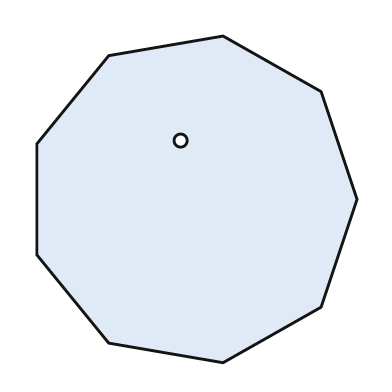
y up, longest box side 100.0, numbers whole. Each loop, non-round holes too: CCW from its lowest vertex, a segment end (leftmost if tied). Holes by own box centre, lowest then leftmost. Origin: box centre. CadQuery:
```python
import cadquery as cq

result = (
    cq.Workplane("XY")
    .moveTo(8.0, -50.0)
    .lineTo(38.0, -33.0)
    .lineTo(49.0, 0.0)
    .lineTo(38.0, 33.0)
    .lineTo(8.0, 50.0)
    .lineTo(-27.0, 44.0)
    .lineTo(-49.0, 17.0)
    .lineTo(-49.0, -17.0)
    .lineTo(-27.0, -44.0)
    .close()
    .moveTo(-5.0, 18.0)
    .circle(2.0)
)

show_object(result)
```